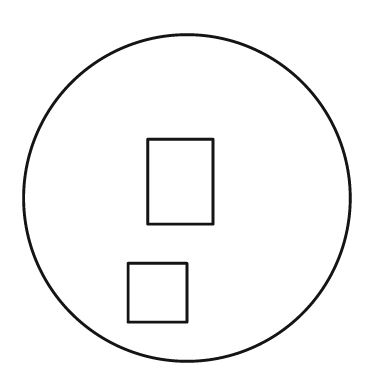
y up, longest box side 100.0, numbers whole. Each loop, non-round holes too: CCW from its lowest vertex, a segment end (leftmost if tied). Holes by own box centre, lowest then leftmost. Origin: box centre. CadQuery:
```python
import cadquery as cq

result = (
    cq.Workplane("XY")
    .moveTo(0.0, 0.0)
    .circle(50.0)
    .moveTo(-18.0, -38.0)
    .lineTo(0.0, -38.0)
    .lineTo(0.0, -20.0)
    .lineTo(-18.0, -20.0)
    .close()
    .moveTo(-12.0, -8.0)
    .lineTo(8.0, -8.0)
    .lineTo(8.0, 18.0)
    .lineTo(-12.0, 18.0)
    .close()
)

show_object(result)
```